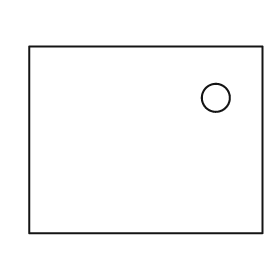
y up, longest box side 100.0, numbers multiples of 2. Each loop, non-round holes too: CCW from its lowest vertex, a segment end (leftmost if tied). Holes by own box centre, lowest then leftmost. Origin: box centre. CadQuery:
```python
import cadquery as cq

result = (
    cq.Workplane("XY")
    .moveTo(-50.0, -40.0)
    .lineTo(50.0, -40.0)
    .lineTo(50.0, 40.0)
    .lineTo(-50.0, 40.0)
    .close()
    .moveTo(30.0, 18.0)
    .circle(6.0)
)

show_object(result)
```